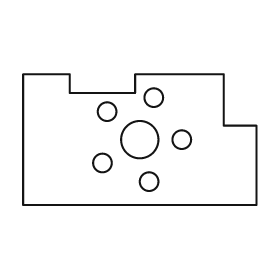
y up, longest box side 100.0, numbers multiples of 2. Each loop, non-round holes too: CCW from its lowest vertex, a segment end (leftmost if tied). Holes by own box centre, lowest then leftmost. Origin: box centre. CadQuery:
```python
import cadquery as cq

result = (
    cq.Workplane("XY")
    .moveTo(-50.0, -28.0)
    .lineTo(50.0, -28.0)
    .lineTo(50.0, 6.0)
    .lineTo(36.0, 6.0)
    .lineTo(36.0, 28.0)
    .lineTo(-2.0, 28.0)
    .lineTo(-2.0, 20.0)
    .lineTo(-30.0, 20.0)
    .lineTo(-30.0, 28.0)
    .lineTo(-50.0, 28.0)
    .close()
    .moveTo(4.0, -18.0)
    .circle(4.0)
    .moveTo(-16.0, -10.0)
    .circle(4.0)
    .moveTo(0.0, 0.0)
    .circle(8.0)
    .moveTo(18.0, 0.0)
    .circle(4.0)
    .moveTo(-14.0, 12.0)
    .circle(4.0)
    .moveTo(6.0, 18.0)
    .circle(4.0)
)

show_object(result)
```